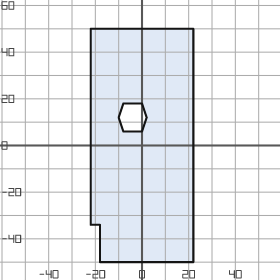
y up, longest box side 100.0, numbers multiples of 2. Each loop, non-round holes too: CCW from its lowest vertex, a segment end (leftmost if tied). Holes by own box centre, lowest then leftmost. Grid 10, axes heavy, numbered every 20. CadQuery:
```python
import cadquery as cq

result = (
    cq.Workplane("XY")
    .moveTo(-18.0, -50.0)
    .lineTo(22.0, -50.0)
    .lineTo(22.0, 50.0)
    .lineTo(-22.0, 50.0)
    .lineTo(-22.0, -34.0)
    .lineTo(-18.0, -34.0)
    .close()
    .moveTo(-8.0, 6.0)
    .lineTo(0.0, 6.0)
    .lineTo(2.0, 12.0)
    .lineTo(0.0, 18.0)
    .lineTo(-8.0, 18.0)
    .lineTo(-10.0, 12.0)
    .close()
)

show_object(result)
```